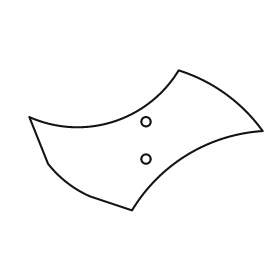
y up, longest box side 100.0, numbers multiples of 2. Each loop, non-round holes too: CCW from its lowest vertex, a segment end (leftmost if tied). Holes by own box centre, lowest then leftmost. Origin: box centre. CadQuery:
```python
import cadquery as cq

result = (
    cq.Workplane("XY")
    .moveTo(-6.0, -30.0)
    .threePointArc((18.0, -6.0), (50.0, 4.0))
    .threePointArc((34.0, 20.0), (14.0, 30.0))
    .threePointArc((-14.0, 8.0), (-50.0, 10.0))
    .lineTo(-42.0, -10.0)
    .threePointArc((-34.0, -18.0), (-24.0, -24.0))
    .close()
    .moveTo(0.0, -8.0)
    .circle(2.0)
    .moveTo(0.0, 8.0)
    .circle(2.0)
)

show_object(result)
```